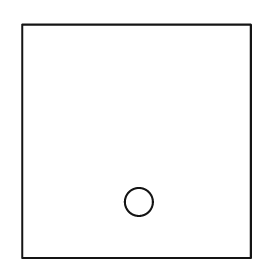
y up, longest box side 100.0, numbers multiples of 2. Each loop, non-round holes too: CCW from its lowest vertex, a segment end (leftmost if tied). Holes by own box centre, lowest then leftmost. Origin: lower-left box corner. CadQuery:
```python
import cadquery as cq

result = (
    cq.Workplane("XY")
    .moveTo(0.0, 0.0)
    .lineTo(98.0, 0.0)
    .lineTo(98.0, 100.0)
    .lineTo(0.0, 100.0)
    .close()
    .moveTo(50.0, 24.0)
    .circle(6.0)
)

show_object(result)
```